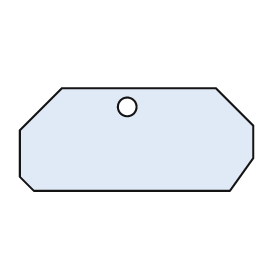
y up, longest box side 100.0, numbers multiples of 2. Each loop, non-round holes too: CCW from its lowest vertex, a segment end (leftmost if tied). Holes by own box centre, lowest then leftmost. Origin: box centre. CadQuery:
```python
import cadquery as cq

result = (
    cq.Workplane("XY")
    .moveTo(-44.0, -22.0)
    .lineTo(40.0, -22.0)
    .lineTo(50.0, -8.0)
    .lineTo(50.0, 6.0)
    .lineTo(34.0, 22.0)
    .lineTo(-32.0, 22.0)
    .lineTo(-50.0, 4.0)
    .lineTo(-50.0, -16.0)
    .close()
    .moveTo(-4.0, 14.0)
    .circle(4.0)
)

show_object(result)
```